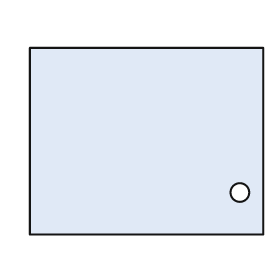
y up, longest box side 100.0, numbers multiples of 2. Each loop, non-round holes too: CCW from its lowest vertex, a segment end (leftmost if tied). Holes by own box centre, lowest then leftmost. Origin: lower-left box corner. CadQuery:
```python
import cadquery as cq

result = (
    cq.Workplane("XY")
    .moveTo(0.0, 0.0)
    .lineTo(100.0, 0.0)
    .lineTo(100.0, 80.0)
    .lineTo(0.0, 80.0)
    .close()
    .moveTo(90.0, 18.0)
    .circle(4.0)
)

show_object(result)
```